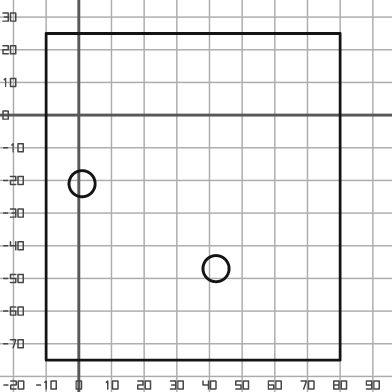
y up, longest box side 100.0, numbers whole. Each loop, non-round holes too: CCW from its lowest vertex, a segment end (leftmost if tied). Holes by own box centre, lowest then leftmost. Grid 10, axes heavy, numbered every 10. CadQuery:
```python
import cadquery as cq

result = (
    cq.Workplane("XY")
    .moveTo(-10.0, -75.0)
    .lineTo(80.0, -75.0)
    .lineTo(80.0, 25.0)
    .lineTo(-10.0, 25.0)
    .close()
    .moveTo(42.0, -47.0)
    .circle(4.0)
    .moveTo(1.0, -21.0)
    .circle(4.0)
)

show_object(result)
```